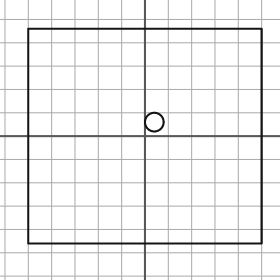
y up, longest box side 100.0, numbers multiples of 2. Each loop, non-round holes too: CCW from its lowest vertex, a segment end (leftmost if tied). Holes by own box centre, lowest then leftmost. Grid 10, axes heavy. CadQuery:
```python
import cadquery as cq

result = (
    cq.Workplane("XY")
    .moveTo(-50.0, -46.0)
    .lineTo(50.0, -46.0)
    .lineTo(50.0, 46.0)
    .lineTo(-50.0, 46.0)
    .close()
    .moveTo(4.0, 6.0)
    .circle(4.0)
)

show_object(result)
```